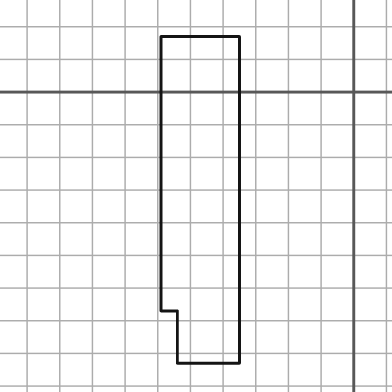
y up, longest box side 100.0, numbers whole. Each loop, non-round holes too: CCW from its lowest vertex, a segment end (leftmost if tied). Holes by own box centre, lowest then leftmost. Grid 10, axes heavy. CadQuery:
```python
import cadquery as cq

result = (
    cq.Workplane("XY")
    .moveTo(-54.0, -83.0)
    .lineTo(-35.0, -83.0)
    .lineTo(-35.0, 17.0)
    .lineTo(-59.0, 17.0)
    .lineTo(-59.0, -67.0)
    .lineTo(-54.0, -67.0)
    .close()
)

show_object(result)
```